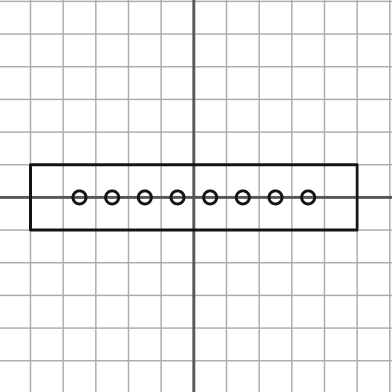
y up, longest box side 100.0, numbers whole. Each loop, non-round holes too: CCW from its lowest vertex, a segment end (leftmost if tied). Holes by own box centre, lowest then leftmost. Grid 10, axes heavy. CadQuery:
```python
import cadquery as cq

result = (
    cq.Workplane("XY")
    .moveTo(-50.0, -10.0)
    .lineTo(50.0, -10.0)
    .lineTo(50.0, 10.0)
    .lineTo(-50.0, 10.0)
    .close()
    .moveTo(-35.0, 0.0)
    .circle(2.0)
    .moveTo(-25.0, 0.0)
    .circle(2.0)
    .moveTo(-15.0, 0.0)
    .circle(2.0)
    .moveTo(-5.0, 0.0)
    .circle(2.0)
    .moveTo(5.0, 0.0)
    .circle(2.0)
    .moveTo(15.0, 0.0)
    .circle(2.0)
    .moveTo(25.0, 0.0)
    .circle(2.0)
    .moveTo(35.0, 0.0)
    .circle(2.0)
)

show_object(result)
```